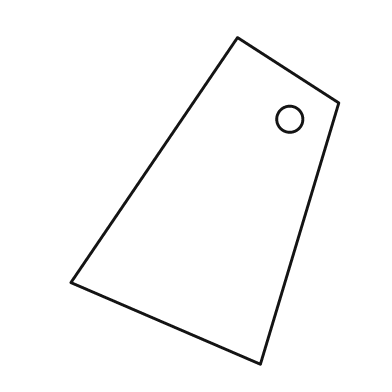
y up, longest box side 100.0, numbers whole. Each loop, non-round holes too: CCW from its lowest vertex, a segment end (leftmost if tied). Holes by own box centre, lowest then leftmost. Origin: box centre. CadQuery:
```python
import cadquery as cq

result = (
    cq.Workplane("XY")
    .moveTo(17.0, -50.0)
    .lineTo(41.0, 30.0)
    .lineTo(10.0, 50.0)
    .lineTo(-41.0, -25.0)
    .close()
    .moveTo(26.0, 25.0)
    .circle(4.0)
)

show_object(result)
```